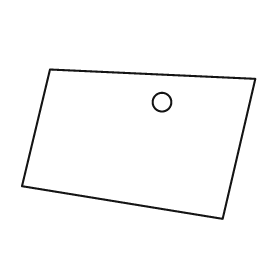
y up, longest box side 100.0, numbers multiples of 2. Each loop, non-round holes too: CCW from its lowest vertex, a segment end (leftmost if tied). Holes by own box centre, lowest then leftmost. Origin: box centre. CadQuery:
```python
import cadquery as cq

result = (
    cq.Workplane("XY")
    .moveTo(36.0, -32.0)
    .lineTo(50.0, 28.0)
    .lineTo(-38.0, 32.0)
    .lineTo(-50.0, -18.0)
    .close()
    .moveTo(10.0, 18.0)
    .circle(4.0)
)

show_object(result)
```